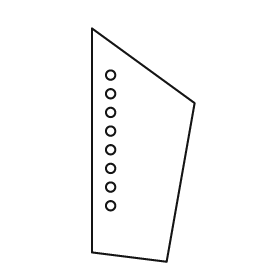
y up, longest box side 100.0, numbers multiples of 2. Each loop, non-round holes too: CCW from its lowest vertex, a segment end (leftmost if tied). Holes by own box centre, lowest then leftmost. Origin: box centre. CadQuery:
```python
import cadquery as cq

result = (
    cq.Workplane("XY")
    .moveTo(10.0, -50.0)
    .lineTo(22.0, 18.0)
    .lineTo(-22.0, 50.0)
    .lineTo(-22.0, -46.0)
    .close()
    .moveTo(-14.0, -26.0)
    .circle(2.0)
    .moveTo(-14.0, -18.0)
    .circle(2.0)
    .moveTo(-14.0, -10.0)
    .circle(2.0)
    .moveTo(-14.0, -2.0)
    .circle(2.0)
    .moveTo(-14.0, 6.0)
    .circle(2.0)
    .moveTo(-14.0, 14.0)
    .circle(2.0)
    .moveTo(-14.0, 22.0)
    .circle(2.0)
    .moveTo(-14.0, 30.0)
    .circle(2.0)
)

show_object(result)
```